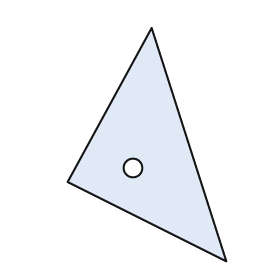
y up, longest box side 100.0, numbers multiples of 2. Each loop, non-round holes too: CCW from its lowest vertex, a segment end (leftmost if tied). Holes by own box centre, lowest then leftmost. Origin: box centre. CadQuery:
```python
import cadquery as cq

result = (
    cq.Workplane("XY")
    .moveTo(34.0, -50.0)
    .lineTo(2.0, 50.0)
    .lineTo(-34.0, -16.0)
    .close()
    .moveTo(-6.0, -10.0)
    .circle(4.0)
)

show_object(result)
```